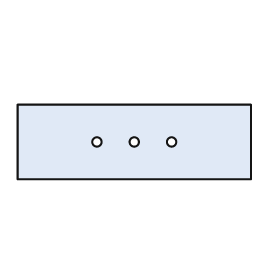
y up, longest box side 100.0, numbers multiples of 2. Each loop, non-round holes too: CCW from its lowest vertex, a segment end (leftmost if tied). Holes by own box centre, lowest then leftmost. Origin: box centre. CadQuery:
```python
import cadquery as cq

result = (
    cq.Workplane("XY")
    .moveTo(-50.0, -16.0)
    .lineTo(50.0, -16.0)
    .lineTo(50.0, 16.0)
    .lineTo(-50.0, 16.0)
    .close()
    .moveTo(-16.0, 0.0)
    .circle(2.0)
    .moveTo(0.0, 0.0)
    .circle(2.0)
    .moveTo(16.0, 0.0)
    .circle(2.0)
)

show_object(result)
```